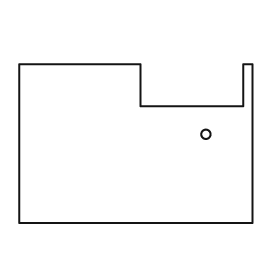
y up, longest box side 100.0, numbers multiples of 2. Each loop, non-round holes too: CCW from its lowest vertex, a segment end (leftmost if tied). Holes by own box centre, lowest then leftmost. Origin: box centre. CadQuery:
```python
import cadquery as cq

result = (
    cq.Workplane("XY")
    .moveTo(-50.0, -34.0)
    .lineTo(50.0, -34.0)
    .lineTo(50.0, 34.0)
    .lineTo(46.0, 34.0)
    .lineTo(46.0, 16.0)
    .lineTo(2.0, 16.0)
    .lineTo(2.0, 34.0)
    .lineTo(-50.0, 34.0)
    .close()
    .moveTo(30.0, 4.0)
    .circle(2.0)
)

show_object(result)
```